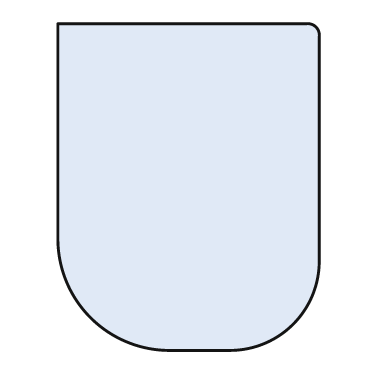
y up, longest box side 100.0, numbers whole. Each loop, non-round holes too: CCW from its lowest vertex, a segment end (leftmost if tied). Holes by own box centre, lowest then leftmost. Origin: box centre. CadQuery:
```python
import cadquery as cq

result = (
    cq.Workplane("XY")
    .moveTo(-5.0, -50.0)
    .lineTo(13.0, -50.0)
    .threePointArc((32.0, -42.0), (40.0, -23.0))
    .lineTo(40.0, 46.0)
    .threePointArc((39.0, 49.0), (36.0, 50.0))
    .lineTo(-40.0, 50.0)
    .lineTo(-40.0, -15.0)
    .threePointArc((-30.0, -40.0), (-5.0, -50.0))
    .close()
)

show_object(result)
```